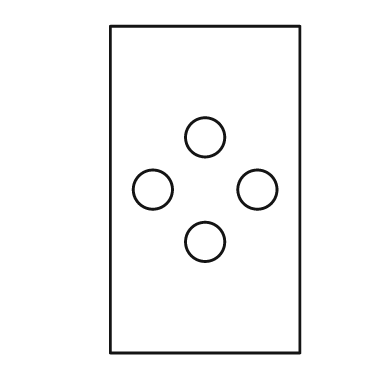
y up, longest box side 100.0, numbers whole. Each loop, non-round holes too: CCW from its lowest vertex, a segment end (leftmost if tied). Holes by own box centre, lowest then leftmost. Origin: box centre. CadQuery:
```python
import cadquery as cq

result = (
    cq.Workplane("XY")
    .moveTo(-29.0, -50.0)
    .lineTo(29.0, -50.0)
    .lineTo(29.0, 50.0)
    .lineTo(-29.0, 50.0)
    .close()
    .moveTo(0.0, -16.0)
    .circle(6.0)
    .moveTo(-16.0, 0.0)
    .circle(6.0)
    .moveTo(16.0, 0.0)
    .circle(6.0)
    .moveTo(0.0, 16.0)
    .circle(6.0)
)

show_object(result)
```